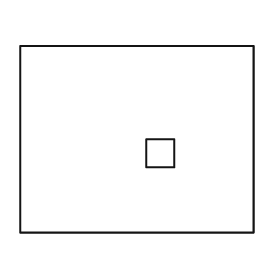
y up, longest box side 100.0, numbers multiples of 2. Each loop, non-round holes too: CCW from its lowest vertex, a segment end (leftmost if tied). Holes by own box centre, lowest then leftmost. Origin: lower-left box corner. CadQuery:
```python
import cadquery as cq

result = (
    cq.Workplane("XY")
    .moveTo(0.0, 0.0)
    .lineTo(100.0, 0.0)
    .lineTo(100.0, 80.0)
    .lineTo(0.0, 80.0)
    .close()
    .moveTo(54.0, 28.0)
    .lineTo(66.0, 28.0)
    .lineTo(66.0, 40.0)
    .lineTo(54.0, 40.0)
    .close()
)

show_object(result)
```